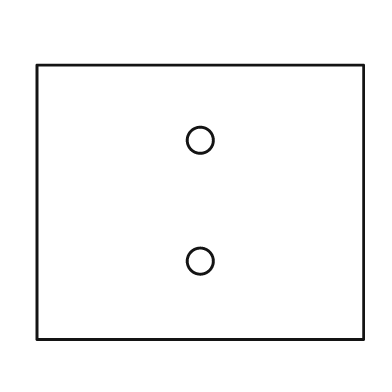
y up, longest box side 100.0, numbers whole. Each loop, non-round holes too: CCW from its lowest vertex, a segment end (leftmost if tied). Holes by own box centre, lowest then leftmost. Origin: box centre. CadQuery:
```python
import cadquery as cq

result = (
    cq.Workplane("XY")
    .moveTo(-50.0, -42.0)
    .lineTo(50.0, -42.0)
    .lineTo(50.0, 42.0)
    .lineTo(-50.0, 42.0)
    .close()
    .moveTo(0.0, -18.0)
    .circle(4.0)
    .moveTo(0.0, 19.0)
    .circle(4.0)
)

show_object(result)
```